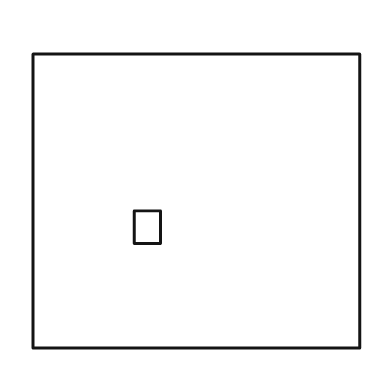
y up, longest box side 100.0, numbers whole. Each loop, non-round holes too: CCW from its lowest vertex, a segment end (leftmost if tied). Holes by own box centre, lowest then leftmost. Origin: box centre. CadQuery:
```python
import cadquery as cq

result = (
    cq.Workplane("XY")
    .moveTo(-50.0, -45.0)
    .lineTo(50.0, -45.0)
    .lineTo(50.0, 45.0)
    .lineTo(-50.0, 45.0)
    .close()
    .moveTo(-19.0, -13.0)
    .lineTo(-11.0, -13.0)
    .lineTo(-11.0, -3.0)
    .lineTo(-19.0, -3.0)
    .close()
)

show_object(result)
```